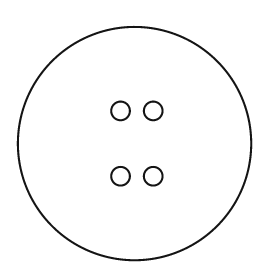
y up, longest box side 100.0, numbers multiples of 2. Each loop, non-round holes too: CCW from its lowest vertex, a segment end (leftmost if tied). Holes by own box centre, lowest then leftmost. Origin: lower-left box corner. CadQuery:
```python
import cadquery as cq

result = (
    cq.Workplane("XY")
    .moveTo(50.0, 50.0)
    .circle(50.0)
    .moveTo(44.0, 36.0)
    .circle(4.0)
    .moveTo(58.0, 36.0)
    .circle(4.0)
    .moveTo(44.0, 64.0)
    .circle(4.0)
    .moveTo(58.0, 64.0)
    .circle(4.0)
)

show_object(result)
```